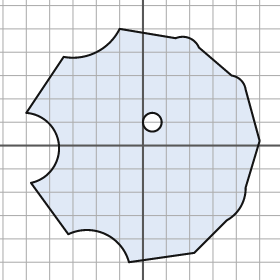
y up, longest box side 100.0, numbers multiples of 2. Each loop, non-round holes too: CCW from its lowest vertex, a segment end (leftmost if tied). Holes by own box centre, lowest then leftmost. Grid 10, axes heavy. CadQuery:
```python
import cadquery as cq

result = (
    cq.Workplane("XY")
    .moveTo(-6.0, -50.0)
    .lineTo(22.0, -46.0)
    .lineTo(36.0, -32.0)
    .threePointArc((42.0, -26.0), (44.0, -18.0))
    .lineTo(50.0, 2.0)
    .lineTo(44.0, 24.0)
    .threePointArc((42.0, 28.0), (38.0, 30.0))
    .lineTo(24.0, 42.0)
    .threePointArc((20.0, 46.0), (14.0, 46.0))
    .lineTo(-10.0, 50.0)
    .threePointArc((-20.0, 40.0), (-34.0, 38.0))
    .lineTo(-50.0, 14.0)
    .threePointArc((-36.0, 0.0), (-48.0, -16.0))
    .lineTo(-32.0, -38.0)
    .threePointArc((-16.0, -38.0), (-6.0, -50.0))
    .close()
    .moveTo(4.0, 10.0)
    .circle(4.0)
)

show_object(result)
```